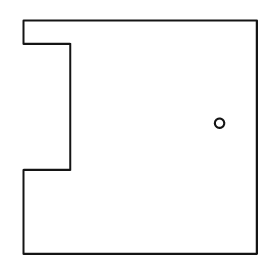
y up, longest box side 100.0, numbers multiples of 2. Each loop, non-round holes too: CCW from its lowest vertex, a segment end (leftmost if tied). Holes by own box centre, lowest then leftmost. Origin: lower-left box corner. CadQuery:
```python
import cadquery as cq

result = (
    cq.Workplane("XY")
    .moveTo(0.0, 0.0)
    .lineTo(100.0, 0.0)
    .lineTo(100.0, 100.0)
    .lineTo(0.0, 100.0)
    .lineTo(0.0, 90.0)
    .lineTo(20.0, 90.0)
    .lineTo(20.0, 36.0)
    .lineTo(0.0, 36.0)
    .close()
    .moveTo(84.0, 56.0)
    .circle(2.0)
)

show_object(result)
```